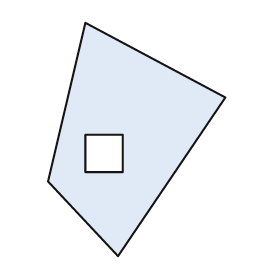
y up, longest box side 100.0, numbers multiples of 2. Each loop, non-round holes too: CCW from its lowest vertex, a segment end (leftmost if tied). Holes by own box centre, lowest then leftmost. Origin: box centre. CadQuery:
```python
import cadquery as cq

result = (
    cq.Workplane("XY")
    .moveTo(-8.0, -50.0)
    .lineTo(38.0, 18.0)
    .lineTo(-22.0, 50.0)
    .lineTo(-38.0, -18.0)
    .close()
    .moveTo(-22.0, -14.0)
    .lineTo(-6.0, -14.0)
    .lineTo(-6.0, 2.0)
    .lineTo(-22.0, 2.0)
    .close()
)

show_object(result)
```